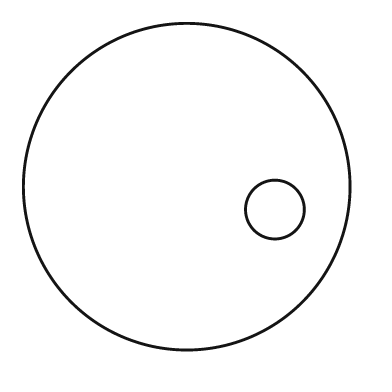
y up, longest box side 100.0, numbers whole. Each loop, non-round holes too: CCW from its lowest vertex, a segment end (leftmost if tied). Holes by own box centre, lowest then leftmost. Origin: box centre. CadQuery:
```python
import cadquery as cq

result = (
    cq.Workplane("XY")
    .moveTo(0.0, 0.0)
    .circle(50.0)
    .moveTo(27.0, -7.0)
    .circle(9.0)
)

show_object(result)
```